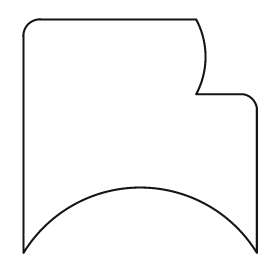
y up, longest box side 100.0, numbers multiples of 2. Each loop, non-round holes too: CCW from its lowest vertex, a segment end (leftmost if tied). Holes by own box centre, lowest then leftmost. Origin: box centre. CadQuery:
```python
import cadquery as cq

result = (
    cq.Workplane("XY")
    .moveTo(-50.0, -50.0)
    .threePointArc((0.0, -22.0), (50.0, -50.0))
    .lineTo(50.0, 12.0)
    .threePointArc((48.0, 16.0), (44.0, 18.0))
    .lineTo(24.0, 18.0)
    .threePointArc((28.0, 34.0), (24.0, 50.0))
    .lineTo(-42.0, 50.0)
    .threePointArc((-48.0, 48.0), (-50.0, 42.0))
    .close()
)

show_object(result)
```